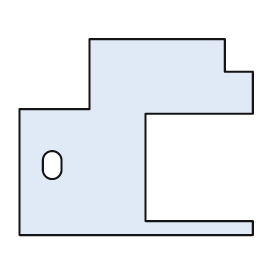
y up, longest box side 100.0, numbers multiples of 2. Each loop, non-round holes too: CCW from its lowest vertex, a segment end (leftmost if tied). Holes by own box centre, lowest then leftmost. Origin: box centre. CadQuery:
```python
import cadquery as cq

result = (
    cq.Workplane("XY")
    .moveTo(-50.0, -42.0)
    .lineTo(50.0, -42.0)
    .lineTo(50.0, -36.0)
    .lineTo(4.0, -36.0)
    .lineTo(4.0, 10.0)
    .lineTo(50.0, 10.0)
    .lineTo(50.0, 28.0)
    .lineTo(38.0, 28.0)
    .lineTo(38.0, 42.0)
    .lineTo(-20.0, 42.0)
    .lineTo(-20.0, 12.0)
    .lineTo(-50.0, 12.0)
    .close()
    .moveTo(-40.0, -14.0)
    .threePointArc((-36.0, -18.0), (-32.0, -14.0))
    .lineTo(-32.0, -10.0)
    .threePointArc((-36.0, -6.0), (-40.0, -10.0))
    .close()
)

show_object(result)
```